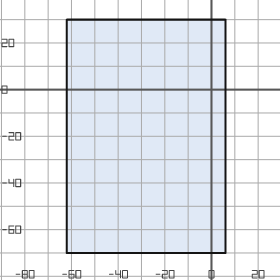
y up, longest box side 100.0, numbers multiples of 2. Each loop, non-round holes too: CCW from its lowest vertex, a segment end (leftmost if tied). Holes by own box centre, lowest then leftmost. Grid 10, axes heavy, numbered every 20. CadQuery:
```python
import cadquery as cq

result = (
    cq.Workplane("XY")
    .moveTo(-62.0, -70.0)
    .lineTo(6.0, -70.0)
    .lineTo(6.0, 30.0)
    .lineTo(-62.0, 30.0)
    .close()
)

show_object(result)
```